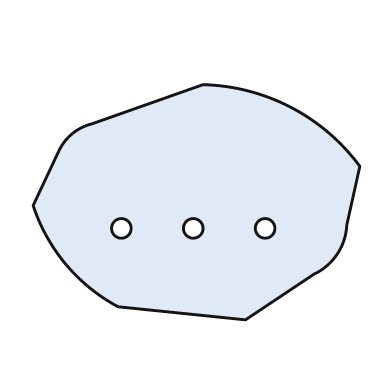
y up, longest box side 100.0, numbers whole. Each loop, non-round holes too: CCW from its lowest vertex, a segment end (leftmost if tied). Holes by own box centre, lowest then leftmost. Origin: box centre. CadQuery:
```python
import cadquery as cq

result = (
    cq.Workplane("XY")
    .moveTo(15.0, -36.0)
    .lineTo(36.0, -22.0)
    .threePointArc((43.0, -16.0), (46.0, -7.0))
    .lineTo(50.0, 11.0)
    .threePointArc((29.0, 29.0), (2.0, 36.0))
    .lineTo(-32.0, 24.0)
    .threePointArc((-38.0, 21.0), (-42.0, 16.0))
    .lineTo(-50.0, -1.0)
    .threePointArc((-40.0, -19.0), (-24.0, -32.0))
    .close()
    .moveTo(-23.0, -8.0)
    .circle(3.0)
    .moveTo(-1.0, -8.0)
    .circle(3.0)
    .moveTo(21.0, -8.0)
    .circle(3.0)
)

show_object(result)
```